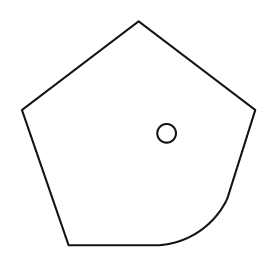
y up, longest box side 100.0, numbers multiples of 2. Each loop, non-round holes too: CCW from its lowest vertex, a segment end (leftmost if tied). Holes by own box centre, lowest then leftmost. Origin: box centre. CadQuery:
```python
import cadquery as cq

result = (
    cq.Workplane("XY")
    .moveTo(-30.0, -48.0)
    .lineTo(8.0, -48.0)
    .threePointArc((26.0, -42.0), (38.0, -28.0))
    .lineTo(50.0, 10.0)
    .lineTo(0.0, 48.0)
    .lineTo(-50.0, 10.0)
    .close()
    .moveTo(12.0, 0.0)
    .circle(4.0)
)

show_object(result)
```